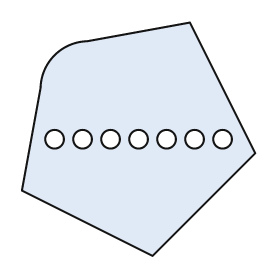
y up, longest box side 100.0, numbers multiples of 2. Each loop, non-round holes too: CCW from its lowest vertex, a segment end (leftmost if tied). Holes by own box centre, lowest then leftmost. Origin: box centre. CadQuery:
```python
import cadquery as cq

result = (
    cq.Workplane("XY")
    .moveTo(6.0, -50.0)
    .lineTo(50.0, -6.0)
    .lineTo(22.0, 50.0)
    .lineTo(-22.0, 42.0)
    .threePointArc((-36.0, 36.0), (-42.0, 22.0))
    .lineTo(-50.0, -22.0)
    .close()
    .moveTo(-36.0, 0.0)
    .circle(4.0)
    .moveTo(-24.0, 0.0)
    .circle(4.0)
    .moveTo(-12.0, 0.0)
    .circle(4.0)
    .moveTo(0.0, 0.0)
    .circle(4.0)
    .moveTo(12.0, 0.0)
    .circle(4.0)
    .moveTo(24.0, 0.0)
    .circle(4.0)
    .moveTo(36.0, 0.0)
    .circle(4.0)
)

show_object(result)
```